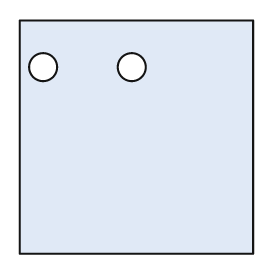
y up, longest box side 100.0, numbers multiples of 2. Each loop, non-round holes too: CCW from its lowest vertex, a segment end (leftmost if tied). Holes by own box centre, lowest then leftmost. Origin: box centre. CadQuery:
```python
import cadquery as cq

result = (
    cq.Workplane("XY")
    .moveTo(-50.0, -50.0)
    .lineTo(50.0, -50.0)
    .lineTo(50.0, 50.0)
    .lineTo(-50.0, 50.0)
    .close()
    .moveTo(-40.0, 30.0)
    .circle(6.0)
    .moveTo(-2.0, 30.0)
    .circle(6.0)
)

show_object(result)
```